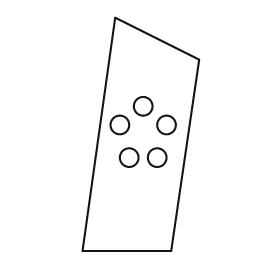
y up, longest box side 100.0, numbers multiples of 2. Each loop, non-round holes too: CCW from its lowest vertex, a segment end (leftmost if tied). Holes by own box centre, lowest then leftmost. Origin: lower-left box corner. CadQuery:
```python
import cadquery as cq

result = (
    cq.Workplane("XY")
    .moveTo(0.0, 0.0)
    .lineTo(38.0, 0.0)
    .lineTo(50.0, 82.0)
    .lineTo(14.0, 100.0)
    .close()
    .moveTo(20.0, 40.0)
    .circle(4.0)
    .moveTo(32.0, 40.0)
    .circle(4.0)
    .moveTo(16.0, 54.0)
    .circle(4.0)
    .moveTo(36.0, 54.0)
    .circle(4.0)
    .moveTo(26.0, 62.0)
    .circle(4.0)
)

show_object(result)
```